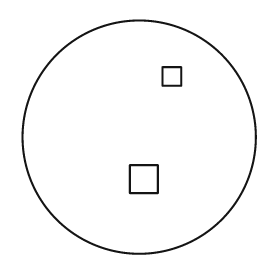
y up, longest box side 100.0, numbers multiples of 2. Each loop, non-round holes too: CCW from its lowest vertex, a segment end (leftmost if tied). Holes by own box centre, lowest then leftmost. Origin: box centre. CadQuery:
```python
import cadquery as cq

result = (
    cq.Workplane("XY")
    .moveTo(0.0, 0.0)
    .circle(50.0)
    .moveTo(-4.0, -24.0)
    .lineTo(8.0, -24.0)
    .lineTo(8.0, -12.0)
    .lineTo(-4.0, -12.0)
    .close()
    .moveTo(10.0, 22.0)
    .lineTo(18.0, 22.0)
    .lineTo(18.0, 30.0)
    .lineTo(10.0, 30.0)
    .close()
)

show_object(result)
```